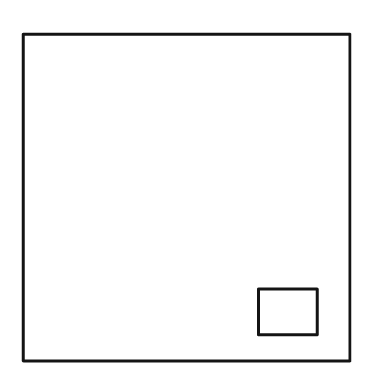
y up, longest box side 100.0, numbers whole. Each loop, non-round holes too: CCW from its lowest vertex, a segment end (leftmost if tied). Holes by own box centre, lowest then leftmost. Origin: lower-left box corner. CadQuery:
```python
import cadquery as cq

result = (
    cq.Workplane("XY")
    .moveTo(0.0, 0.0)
    .lineTo(100.0, 0.0)
    .lineTo(100.0, 100.0)
    .lineTo(0.0, 100.0)
    .close()
    .moveTo(72.0, 8.0)
    .lineTo(90.0, 8.0)
    .lineTo(90.0, 22.0)
    .lineTo(72.0, 22.0)
    .close()
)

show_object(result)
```